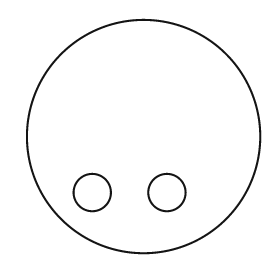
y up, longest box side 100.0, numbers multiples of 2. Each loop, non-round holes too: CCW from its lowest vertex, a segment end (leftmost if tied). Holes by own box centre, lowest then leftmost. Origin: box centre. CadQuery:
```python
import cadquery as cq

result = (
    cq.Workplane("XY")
    .moveTo(0.0, 0.0)
    .circle(50.0)
    .moveTo(-22.0, -24.0)
    .circle(8.0)
    .moveTo(10.0, -24.0)
    .circle(8.0)
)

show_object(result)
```